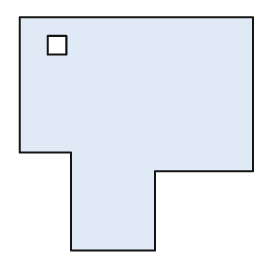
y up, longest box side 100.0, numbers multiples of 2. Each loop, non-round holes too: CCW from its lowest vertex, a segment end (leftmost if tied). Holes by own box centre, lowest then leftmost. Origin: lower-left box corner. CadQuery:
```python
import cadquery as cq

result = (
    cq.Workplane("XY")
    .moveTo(22.0, 0.0)
    .lineTo(58.0, 0.0)
    .lineTo(58.0, 34.0)
    .lineTo(100.0, 34.0)
    .lineTo(100.0, 100.0)
    .lineTo(0.0, 100.0)
    .lineTo(0.0, 42.0)
    .lineTo(22.0, 42.0)
    .close()
    .moveTo(12.0, 84.0)
    .lineTo(20.0, 84.0)
    .lineTo(20.0, 92.0)
    .lineTo(12.0, 92.0)
    .close()
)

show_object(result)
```